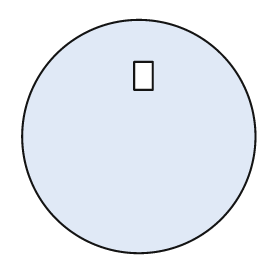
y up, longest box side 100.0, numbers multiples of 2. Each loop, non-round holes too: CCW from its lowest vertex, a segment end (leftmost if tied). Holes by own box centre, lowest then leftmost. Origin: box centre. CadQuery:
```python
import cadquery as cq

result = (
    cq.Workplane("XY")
    .moveTo(0.0, 0.0)
    .circle(50.0)
    .moveTo(-2.0, 20.0)
    .lineTo(6.0, 20.0)
    .lineTo(6.0, 32.0)
    .lineTo(-2.0, 32.0)
    .close()
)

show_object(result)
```